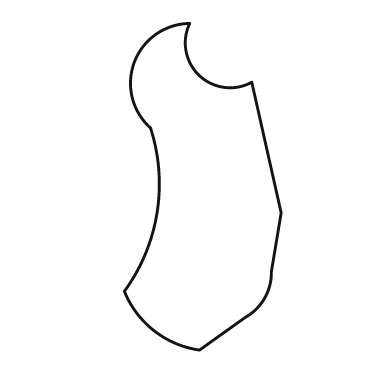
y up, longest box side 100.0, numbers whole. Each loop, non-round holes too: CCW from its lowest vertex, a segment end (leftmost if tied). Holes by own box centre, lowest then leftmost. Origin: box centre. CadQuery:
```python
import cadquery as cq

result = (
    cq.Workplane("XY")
    .moveTo(-1.0, -50.0)
    .lineTo(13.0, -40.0)
    .threePointArc((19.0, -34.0), (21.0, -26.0))
    .lineTo(24.0, -8.0)
    .lineTo(15.0, 32.0)
    .threePointArc((-1.0, 34.0), (-4.0, 50.0))
    .threePointArc((-21.0, 38.0), (-16.0, 18.0))
    .threePointArc((-14.0, -8.0), (-24.0, -32.0))
    .threePointArc((-15.0, -44.0), (-1.0, -50.0))
    .close()
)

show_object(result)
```